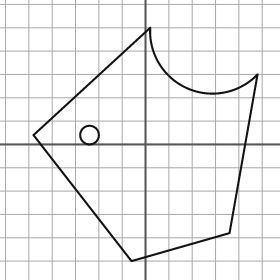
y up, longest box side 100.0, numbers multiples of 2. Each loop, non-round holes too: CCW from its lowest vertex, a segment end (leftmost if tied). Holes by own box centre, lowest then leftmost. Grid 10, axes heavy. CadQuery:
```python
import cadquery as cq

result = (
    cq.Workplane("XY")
    .moveTo(-6.0, -50.0)
    .lineTo(36.0, -38.0)
    .lineTo(48.0, 30.0)
    .threePointArc((18.0, 24.0), (2.0, 50.0))
    .lineTo(-48.0, 4.0)
    .close()
    .moveTo(-24.0, 4.0)
    .circle(4.0)
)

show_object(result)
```